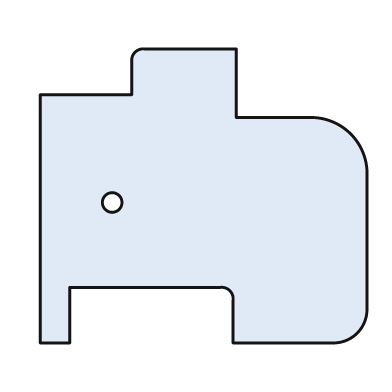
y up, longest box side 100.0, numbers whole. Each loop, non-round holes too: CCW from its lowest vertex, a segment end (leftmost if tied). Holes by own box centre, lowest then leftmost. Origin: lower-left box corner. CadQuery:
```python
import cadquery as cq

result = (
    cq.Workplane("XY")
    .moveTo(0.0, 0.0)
    .lineTo(9.0, 0.0)
    .lineTo(9.0, 17.0)
    .lineTo(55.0, 17.0)
    .threePointArc((58.0, 16.0), (59.0, 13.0))
    .lineTo(59.0, 0.0)
    .lineTo(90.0, 0.0)
    .threePointArc((97.0, 3.0), (100.0, 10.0))
    .lineTo(100.0, 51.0)
    .threePointArc((95.0, 64.0), (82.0, 69.0))
    .lineTo(60.0, 69.0)
    .lineTo(60.0, 90.0)
    .lineTo(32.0, 90.0)
    .threePointArc((29.0, 89.0), (28.0, 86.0))
    .lineTo(28.0, 76.0)
    .lineTo(0.0, 76.0)
    .close()
    .moveTo(22.0, 43.0)
    .circle(3.0)
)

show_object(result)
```